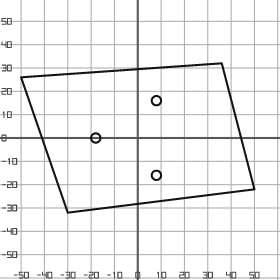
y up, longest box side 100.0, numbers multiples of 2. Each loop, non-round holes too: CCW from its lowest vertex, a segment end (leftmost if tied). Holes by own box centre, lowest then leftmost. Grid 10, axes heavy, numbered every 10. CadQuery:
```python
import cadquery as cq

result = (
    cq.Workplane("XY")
    .moveTo(-30.0, -32.0)
    .lineTo(50.0, -22.0)
    .lineTo(36.0, 32.0)
    .lineTo(-50.0, 26.0)
    .close()
    .moveTo(8.0, -16.0)
    .circle(2.0)
    .moveTo(-18.0, 0.0)
    .circle(2.0)
    .moveTo(8.0, 16.0)
    .circle(2.0)
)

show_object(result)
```